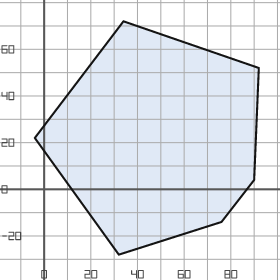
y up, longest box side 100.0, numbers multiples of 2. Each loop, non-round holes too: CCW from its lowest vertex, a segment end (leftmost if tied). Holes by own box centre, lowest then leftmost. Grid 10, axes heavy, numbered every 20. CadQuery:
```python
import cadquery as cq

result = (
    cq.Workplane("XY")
    .moveTo(32.0, -28.0)
    .lineTo(76.0, -14.0)
    .lineTo(90.0, 4.0)
    .lineTo(92.0, 52.0)
    .lineTo(34.0, 72.0)
    .lineTo(-4.0, 22.0)
    .close()
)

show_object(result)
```